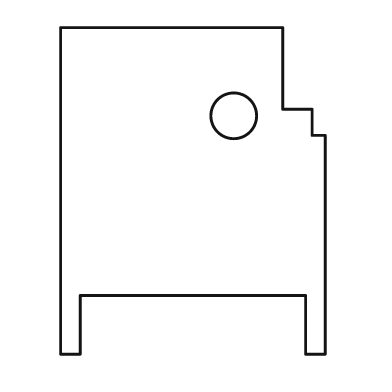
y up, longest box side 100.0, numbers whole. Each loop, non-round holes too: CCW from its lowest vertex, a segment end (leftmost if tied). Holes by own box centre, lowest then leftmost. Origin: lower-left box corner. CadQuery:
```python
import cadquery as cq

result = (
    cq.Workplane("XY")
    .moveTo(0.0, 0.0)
    .lineTo(6.0, 0.0)
    .lineTo(6.0, 18.0)
    .lineTo(75.0, 18.0)
    .lineTo(75.0, 0.0)
    .lineTo(81.0, 0.0)
    .lineTo(81.0, 67.0)
    .lineTo(77.0, 67.0)
    .lineTo(77.0, 75.0)
    .lineTo(68.0, 75.0)
    .lineTo(68.0, 100.0)
    .lineTo(0.0, 100.0)
    .close()
    .moveTo(53.0, 73.0)
    .circle(7.0)
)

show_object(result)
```